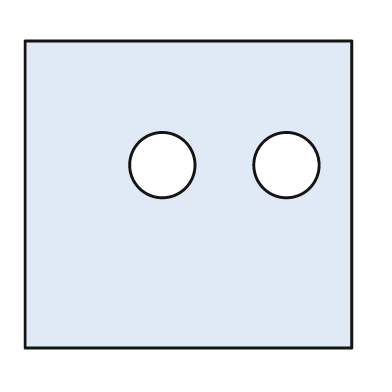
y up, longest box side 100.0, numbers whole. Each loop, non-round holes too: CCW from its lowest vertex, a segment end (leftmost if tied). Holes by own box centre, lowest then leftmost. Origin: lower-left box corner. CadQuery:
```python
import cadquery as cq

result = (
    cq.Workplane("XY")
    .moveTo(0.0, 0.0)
    .lineTo(100.0, 0.0)
    .lineTo(100.0, 94.0)
    .lineTo(0.0, 94.0)
    .close()
    .moveTo(42.0, 56.0)
    .circle(10.0)
    .moveTo(80.0, 56.0)
    .circle(10.0)
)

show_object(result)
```